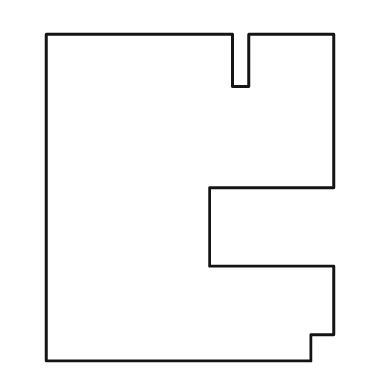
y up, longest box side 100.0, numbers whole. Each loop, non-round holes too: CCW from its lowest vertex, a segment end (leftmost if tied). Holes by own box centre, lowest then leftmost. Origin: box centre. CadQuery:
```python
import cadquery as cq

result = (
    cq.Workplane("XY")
    .moveTo(-44.0, -50.0)
    .lineTo(37.0, -50.0)
    .lineTo(37.0, -42.0)
    .lineTo(44.0, -42.0)
    .lineTo(44.0, -21.0)
    .lineTo(6.0, -21.0)
    .lineTo(6.0, 3.0)
    .lineTo(44.0, 3.0)
    .lineTo(44.0, 50.0)
    .lineTo(18.0, 50.0)
    .lineTo(18.0, 34.0)
    .lineTo(13.0, 34.0)
    .lineTo(13.0, 50.0)
    .lineTo(-44.0, 50.0)
    .close()
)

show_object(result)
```